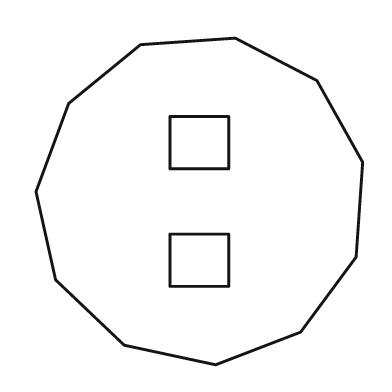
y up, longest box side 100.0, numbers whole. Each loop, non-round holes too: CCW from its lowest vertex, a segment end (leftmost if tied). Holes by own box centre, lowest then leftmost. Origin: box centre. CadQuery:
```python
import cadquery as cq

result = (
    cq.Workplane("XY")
    .moveTo(5.0, -50.0)
    .lineTo(31.0, -40.0)
    .lineTo(48.0, -17.0)
    .lineTo(50.0, 12.0)
    .lineTo(36.0, 37.0)
    .lineTo(11.0, 50.0)
    .lineTo(-18.0, 48.0)
    .lineTo(-40.0, 30.0)
    .lineTo(-50.0, 3.0)
    .lineTo(-44.0, -24.0)
    .lineTo(-23.0, -44.0)
    .close()
    .moveTo(-9.0, -26.0)
    .lineTo(9.0, -26.0)
    .lineTo(9.0, -10.0)
    .lineTo(-9.0, -10.0)
    .close()
    .moveTo(-9.0, 10.0)
    .lineTo(9.0, 10.0)
    .lineTo(9.0, 26.0)
    .lineTo(-9.0, 26.0)
    .close()
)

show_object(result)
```